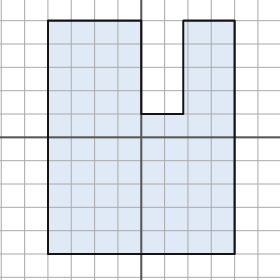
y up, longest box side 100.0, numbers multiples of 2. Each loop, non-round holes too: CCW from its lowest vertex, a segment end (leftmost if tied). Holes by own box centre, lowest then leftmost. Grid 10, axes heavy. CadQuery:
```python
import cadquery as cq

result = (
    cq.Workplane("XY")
    .moveTo(-40.0, -50.0)
    .lineTo(40.0, -50.0)
    .lineTo(40.0, 50.0)
    .lineTo(18.0, 50.0)
    .lineTo(18.0, 10.0)
    .lineTo(0.0, 10.0)
    .lineTo(0.0, 50.0)
    .lineTo(-40.0, 50.0)
    .close()
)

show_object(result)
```